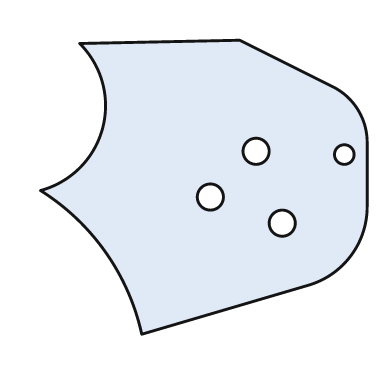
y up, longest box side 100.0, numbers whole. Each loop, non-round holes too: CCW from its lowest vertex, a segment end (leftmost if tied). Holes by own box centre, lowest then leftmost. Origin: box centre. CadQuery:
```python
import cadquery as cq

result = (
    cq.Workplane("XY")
    .moveTo(-19.0, -45.0)
    .lineTo(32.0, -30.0)
    .threePointArc((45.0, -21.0), (50.0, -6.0))
    .lineTo(50.0, 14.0)
    .threePointArc((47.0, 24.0), (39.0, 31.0))
    .lineTo(11.0, 45.0)
    .lineTo(-38.0, 44.0)
    .threePointArc((-31.0, 18.0), (-50.0, -1.0))
    .threePointArc((-30.0, -20.0), (-19.0, -45.0))
    .close()
    .moveTo(24.0, -11.0)
    .circle(4.0)
    .moveTo(2.0, -3.0)
    .circle(4.0)
    .moveTo(43.0, 10.0)
    .circle(3.0)
    .moveTo(16.0, 11.0)
    .circle(4.0)
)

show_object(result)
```